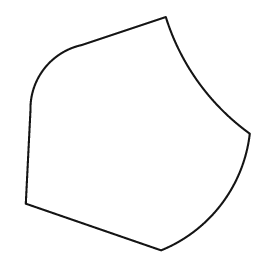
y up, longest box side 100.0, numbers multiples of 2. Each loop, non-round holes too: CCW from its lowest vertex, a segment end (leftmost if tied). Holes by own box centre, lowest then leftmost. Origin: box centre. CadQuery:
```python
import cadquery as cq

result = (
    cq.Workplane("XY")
    .moveTo(10.0, -50.0)
    .threePointArc((36.0, -30.0), (48.0, 0.0))
    .threePointArc((26.0, 22.0), (12.0, 50.0))
    .lineTo(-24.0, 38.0)
    .threePointArc((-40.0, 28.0), (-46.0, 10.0))
    .lineTo(-48.0, -30.0)
    .close()
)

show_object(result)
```